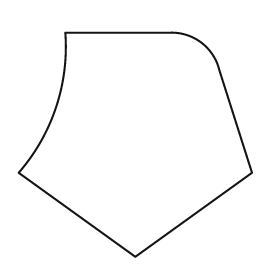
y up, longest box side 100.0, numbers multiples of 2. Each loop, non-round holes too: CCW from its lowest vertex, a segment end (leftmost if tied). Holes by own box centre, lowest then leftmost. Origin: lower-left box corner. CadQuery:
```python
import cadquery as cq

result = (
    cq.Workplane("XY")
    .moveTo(50.0, 0.0)
    .lineTo(100.0, 36.0)
    .lineTo(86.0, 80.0)
    .threePointArc((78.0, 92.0), (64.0, 96.0))
    .lineTo(20.0, 96.0)
    .threePointArc((16.0, 64.0), (0.0, 36.0))
    .close()
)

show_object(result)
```